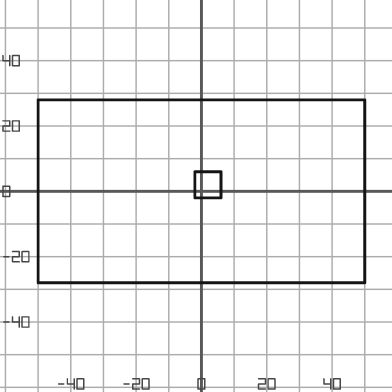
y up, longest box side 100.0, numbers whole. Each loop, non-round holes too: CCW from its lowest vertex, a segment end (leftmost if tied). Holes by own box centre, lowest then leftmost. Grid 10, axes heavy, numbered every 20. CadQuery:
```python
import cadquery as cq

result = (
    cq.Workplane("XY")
    .moveTo(-50.0, -28.0)
    .lineTo(50.0, -28.0)
    .lineTo(50.0, 28.0)
    .lineTo(-50.0, 28.0)
    .close()
    .moveTo(-2.0, -2.0)
    .lineTo(6.0, -2.0)
    .lineTo(6.0, 6.0)
    .lineTo(-2.0, 6.0)
    .close()
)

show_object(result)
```